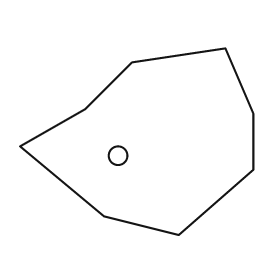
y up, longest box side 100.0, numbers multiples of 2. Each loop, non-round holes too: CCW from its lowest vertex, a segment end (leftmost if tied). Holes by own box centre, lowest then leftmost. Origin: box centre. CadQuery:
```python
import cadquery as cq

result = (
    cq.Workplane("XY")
    .moveTo(18.0, -40.0)
    .lineTo(50.0, -12.0)
    .lineTo(50.0, 12.0)
    .lineTo(38.0, 40.0)
    .lineTo(-2.0, 34.0)
    .lineTo(-22.0, 14.0)
    .lineTo(-50.0, -2.0)
    .lineTo(-14.0, -32.0)
    .close()
    .moveTo(-8.0, -6.0)
    .circle(4.0)
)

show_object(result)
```